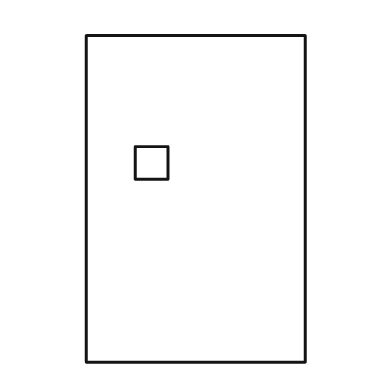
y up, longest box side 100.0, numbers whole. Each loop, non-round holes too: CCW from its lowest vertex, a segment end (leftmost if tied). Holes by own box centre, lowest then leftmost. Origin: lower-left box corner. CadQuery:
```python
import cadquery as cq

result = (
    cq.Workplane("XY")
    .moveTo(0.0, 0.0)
    .lineTo(67.0, 0.0)
    .lineTo(67.0, 100.0)
    .lineTo(0.0, 100.0)
    .close()
    .moveTo(15.0, 56.0)
    .lineTo(25.0, 56.0)
    .lineTo(25.0, 66.0)
    .lineTo(15.0, 66.0)
    .close()
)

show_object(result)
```